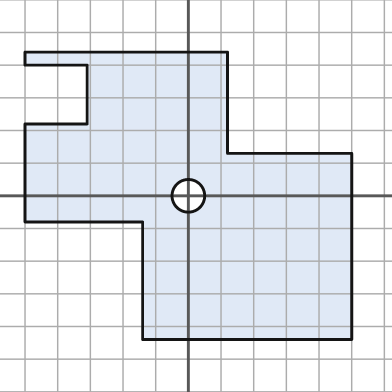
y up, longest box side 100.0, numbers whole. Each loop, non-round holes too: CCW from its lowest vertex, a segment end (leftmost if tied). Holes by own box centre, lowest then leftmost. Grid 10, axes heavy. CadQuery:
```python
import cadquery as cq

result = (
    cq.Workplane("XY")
    .moveTo(-14.0, -44.0)
    .lineTo(50.0, -44.0)
    .lineTo(50.0, 13.0)
    .lineTo(12.0, 13.0)
    .lineTo(12.0, 44.0)
    .lineTo(-50.0, 44.0)
    .lineTo(-50.0, 40.0)
    .lineTo(-31.0, 40.0)
    .lineTo(-31.0, 22.0)
    .lineTo(-50.0, 22.0)
    .lineTo(-50.0, -8.0)
    .lineTo(-14.0, -8.0)
    .close()
    .moveTo(0.0, 0.0)
    .circle(5.0)
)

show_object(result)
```